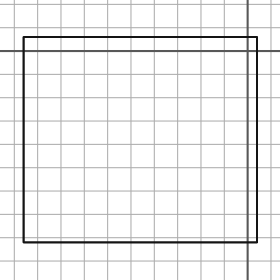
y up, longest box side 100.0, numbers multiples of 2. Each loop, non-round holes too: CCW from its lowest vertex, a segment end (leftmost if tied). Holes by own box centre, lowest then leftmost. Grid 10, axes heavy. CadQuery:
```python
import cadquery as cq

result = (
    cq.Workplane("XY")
    .moveTo(-96.0, -82.0)
    .lineTo(4.0, -82.0)
    .lineTo(4.0, 6.0)
    .lineTo(-96.0, 6.0)
    .close()
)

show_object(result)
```